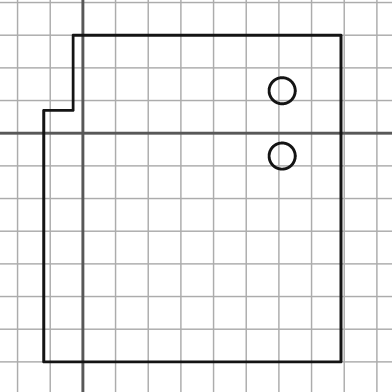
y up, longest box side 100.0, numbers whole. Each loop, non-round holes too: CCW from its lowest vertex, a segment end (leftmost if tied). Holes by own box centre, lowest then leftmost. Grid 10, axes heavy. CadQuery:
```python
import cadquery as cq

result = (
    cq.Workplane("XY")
    .moveTo(-12.0, -70.0)
    .lineTo(79.0, -70.0)
    .lineTo(79.0, 30.0)
    .lineTo(-3.0, 30.0)
    .lineTo(-3.0, 7.0)
    .lineTo(-12.0, 7.0)
    .close()
    .moveTo(61.0, -7.0)
    .circle(4.0)
    .moveTo(61.0, 13.0)
    .circle(4.0)
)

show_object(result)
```